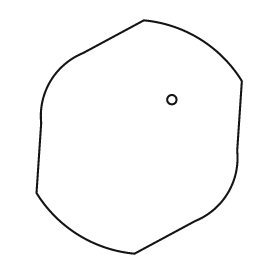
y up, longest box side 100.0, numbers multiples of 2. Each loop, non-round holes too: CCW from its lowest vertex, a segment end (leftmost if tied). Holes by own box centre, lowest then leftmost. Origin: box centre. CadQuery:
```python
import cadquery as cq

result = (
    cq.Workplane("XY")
    .moveTo(-2.0, -50.0)
    .lineTo(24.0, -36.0)
    .threePointArc((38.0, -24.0), (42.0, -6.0))
    .lineTo(44.0, 24.0)
    .threePointArc((26.0, 42.0), (2.0, 50.0))
    .lineTo(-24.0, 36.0)
    .threePointArc((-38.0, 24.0), (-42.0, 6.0))
    .lineTo(-44.0, -24.0)
    .threePointArc((-26.0, -42.0), (-2.0, -50.0))
    .close()
    .moveTo(14.0, 16.0)
    .circle(2.0)
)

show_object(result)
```